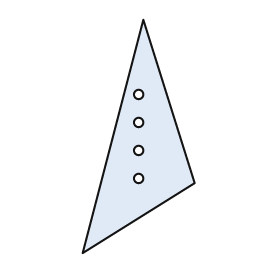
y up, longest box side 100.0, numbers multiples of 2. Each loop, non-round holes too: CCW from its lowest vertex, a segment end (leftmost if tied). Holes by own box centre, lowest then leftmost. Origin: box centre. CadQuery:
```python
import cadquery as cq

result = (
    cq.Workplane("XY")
    .moveTo(-24.0, -50.0)
    .lineTo(24.0, -20.0)
    .lineTo(2.0, 50.0)
    .close()
    .moveTo(0.0, -18.0)
    .circle(2.0)
    .moveTo(0.0, -6.0)
    .circle(2.0)
    .moveTo(0.0, 6.0)
    .circle(2.0)
    .moveTo(0.0, 18.0)
    .circle(2.0)
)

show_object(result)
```